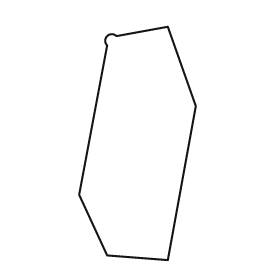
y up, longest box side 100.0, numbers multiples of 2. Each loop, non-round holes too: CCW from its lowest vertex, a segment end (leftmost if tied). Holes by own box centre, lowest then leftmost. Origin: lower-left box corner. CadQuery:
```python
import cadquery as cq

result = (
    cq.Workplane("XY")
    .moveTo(38.0, 0.0)
    .lineTo(50.0, 66.0)
    .lineTo(38.0, 100.0)
    .lineTo(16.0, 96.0)
    .threePointArc((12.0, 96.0), (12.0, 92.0))
    .lineTo(0.0, 28.0)
    .lineTo(12.0, 2.0)
    .close()
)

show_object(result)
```